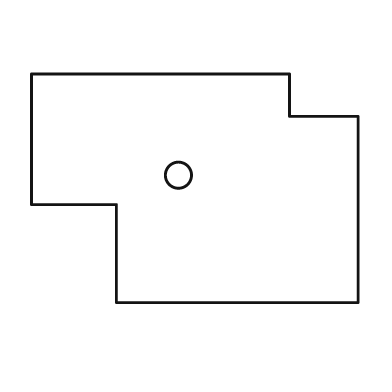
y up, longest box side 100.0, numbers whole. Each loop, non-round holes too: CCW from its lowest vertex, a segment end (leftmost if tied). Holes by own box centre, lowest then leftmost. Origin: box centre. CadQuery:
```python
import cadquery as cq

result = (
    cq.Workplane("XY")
    .moveTo(-24.0, -35.0)
    .lineTo(50.0, -35.0)
    .lineTo(50.0, 22.0)
    .lineTo(29.0, 22.0)
    .lineTo(29.0, 35.0)
    .lineTo(-50.0, 35.0)
    .lineTo(-50.0, -5.0)
    .lineTo(-24.0, -5.0)
    .close()
    .moveTo(-5.0, 4.0)
    .circle(4.0)
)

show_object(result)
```